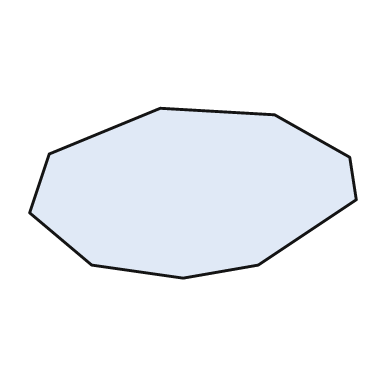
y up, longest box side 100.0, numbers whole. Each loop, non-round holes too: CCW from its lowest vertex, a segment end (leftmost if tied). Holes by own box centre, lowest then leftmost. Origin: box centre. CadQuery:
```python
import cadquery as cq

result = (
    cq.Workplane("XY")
    .moveTo(-3.0, -26.0)
    .lineTo(20.0, -22.0)
    .lineTo(50.0, -2.0)
    .lineTo(48.0, 11.0)
    .lineTo(25.0, 24.0)
    .lineTo(-10.0, 26.0)
    .lineTo(-44.0, 12.0)
    .lineTo(-50.0, -6.0)
    .lineTo(-31.0, -22.0)
    .close()
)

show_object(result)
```